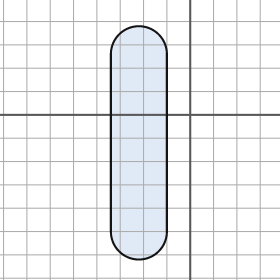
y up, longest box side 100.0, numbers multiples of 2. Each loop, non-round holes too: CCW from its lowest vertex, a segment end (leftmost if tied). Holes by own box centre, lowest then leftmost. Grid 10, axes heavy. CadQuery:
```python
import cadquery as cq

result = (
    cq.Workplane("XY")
    .moveTo(-34.0, -50.0)
    .threePointArc((-22.0, -62.0), (-10.0, -50.0))
    .lineTo(-10.0, 26.0)
    .threePointArc((-22.0, 38.0), (-34.0, 26.0))
    .close()
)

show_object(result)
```